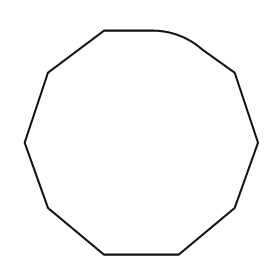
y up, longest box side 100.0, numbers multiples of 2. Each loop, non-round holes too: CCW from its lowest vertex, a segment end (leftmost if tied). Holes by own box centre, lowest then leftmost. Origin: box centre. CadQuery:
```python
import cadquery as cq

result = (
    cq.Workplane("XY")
    .moveTo(-16.0, -48.0)
    .lineTo(16.0, -48.0)
    .lineTo(40.0, -28.0)
    .lineTo(50.0, 0.0)
    .lineTo(40.0, 30.0)
    .lineTo(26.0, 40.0)
    .threePointArc((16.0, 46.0), (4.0, 48.0))
    .lineTo(-16.0, 48.0)
    .lineTo(-40.0, 30.0)
    .lineTo(-50.0, 0.0)
    .lineTo(-40.0, -28.0)
    .close()
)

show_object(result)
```